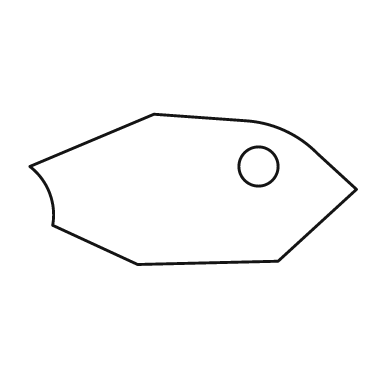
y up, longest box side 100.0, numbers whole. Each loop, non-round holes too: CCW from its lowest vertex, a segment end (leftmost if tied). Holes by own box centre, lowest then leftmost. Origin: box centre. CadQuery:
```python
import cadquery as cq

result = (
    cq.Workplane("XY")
    .moveTo(-17.0, -23.0)
    .lineTo(26.0, -22.0)
    .lineTo(50.0, 0.0)
    .lineTo(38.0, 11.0)
    .threePointArc((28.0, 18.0), (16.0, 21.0))
    .lineTo(-12.0, 23.0)
    .lineTo(-50.0, 7.0)
    .threePointArc((-44.0, -1.0), (-43.0, -11.0))
    .close()
    .moveTo(20.0, 7.0)
    .circle(6.0)
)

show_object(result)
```